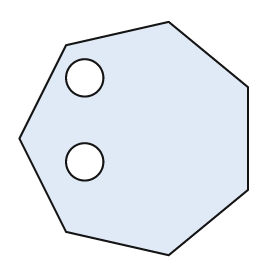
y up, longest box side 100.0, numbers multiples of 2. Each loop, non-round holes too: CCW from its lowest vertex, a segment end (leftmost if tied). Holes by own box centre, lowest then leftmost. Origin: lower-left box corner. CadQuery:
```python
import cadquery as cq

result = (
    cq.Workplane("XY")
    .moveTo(64.0, 0.0)
    .lineTo(98.0, 28.0)
    .lineTo(98.0, 72.0)
    .lineTo(64.0, 100.0)
    .lineTo(20.0, 90.0)
    .lineTo(0.0, 50.0)
    .lineTo(20.0, 10.0)
    .close()
    .moveTo(28.0, 40.0)
    .circle(8.0)
    .moveTo(28.0, 76.0)
    .circle(8.0)
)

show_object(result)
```